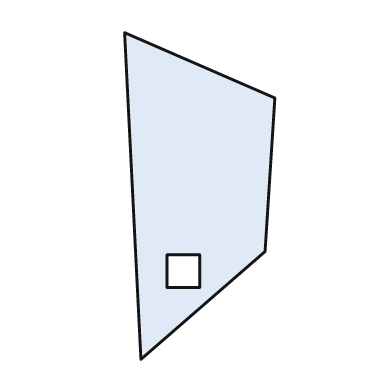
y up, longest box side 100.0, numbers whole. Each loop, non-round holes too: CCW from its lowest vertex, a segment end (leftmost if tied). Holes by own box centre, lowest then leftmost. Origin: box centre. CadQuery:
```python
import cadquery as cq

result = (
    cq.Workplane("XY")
    .moveTo(-18.0, -50.0)
    .lineTo(20.0, -17.0)
    .lineTo(23.0, 30.0)
    .lineTo(-23.0, 50.0)
    .close()
    .moveTo(-10.0, -28.0)
    .lineTo(0.0, -28.0)
    .lineTo(0.0, -18.0)
    .lineTo(-10.0, -18.0)
    .close()
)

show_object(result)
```